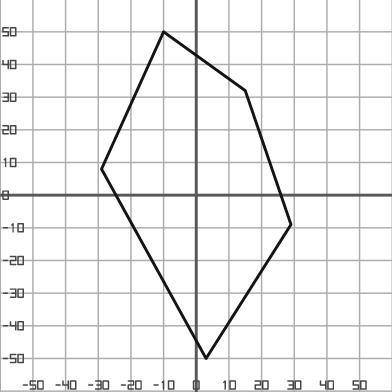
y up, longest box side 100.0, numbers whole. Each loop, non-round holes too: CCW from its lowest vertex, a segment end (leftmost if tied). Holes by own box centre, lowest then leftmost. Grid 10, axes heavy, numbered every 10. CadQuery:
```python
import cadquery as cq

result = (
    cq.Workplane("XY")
    .moveTo(3.0, -50.0)
    .lineTo(29.0, -9.0)
    .lineTo(15.0, 32.0)
    .lineTo(-10.0, 50.0)
    .lineTo(-29.0, 8.0)
    .close()
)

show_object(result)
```